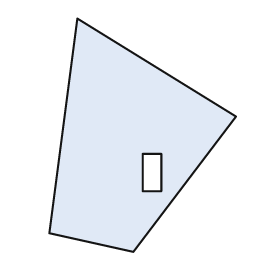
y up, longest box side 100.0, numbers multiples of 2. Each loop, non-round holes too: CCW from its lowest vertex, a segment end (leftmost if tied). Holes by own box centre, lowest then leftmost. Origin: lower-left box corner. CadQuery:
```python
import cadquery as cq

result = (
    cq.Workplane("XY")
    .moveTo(36.0, 0.0)
    .lineTo(80.0, 58.0)
    .lineTo(12.0, 100.0)
    .lineTo(0.0, 8.0)
    .close()
    .moveTo(40.0, 26.0)
    .lineTo(48.0, 26.0)
    .lineTo(48.0, 42.0)
    .lineTo(40.0, 42.0)
    .close()
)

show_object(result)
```